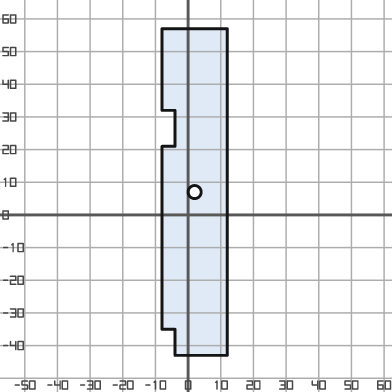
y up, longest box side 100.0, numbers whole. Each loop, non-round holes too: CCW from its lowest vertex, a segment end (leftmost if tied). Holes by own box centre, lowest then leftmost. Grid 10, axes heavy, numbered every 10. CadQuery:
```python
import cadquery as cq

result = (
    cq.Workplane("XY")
    .moveTo(-4.0, -43.0)
    .lineTo(12.0, -43.0)
    .lineTo(12.0, 57.0)
    .lineTo(-8.0, 57.0)
    .lineTo(-8.0, 32.0)
    .lineTo(-4.0, 32.0)
    .lineTo(-4.0, 21.0)
    .lineTo(-8.0, 21.0)
    .lineTo(-8.0, -35.0)
    .lineTo(-4.0, -35.0)
    .close()
    .moveTo(2.0, 7.0)
    .circle(2.0)
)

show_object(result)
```